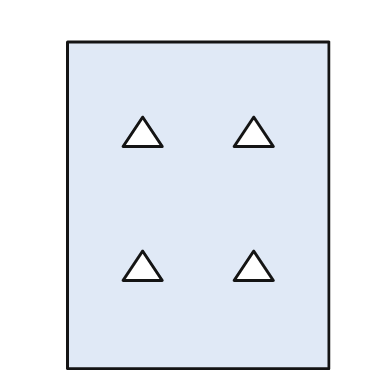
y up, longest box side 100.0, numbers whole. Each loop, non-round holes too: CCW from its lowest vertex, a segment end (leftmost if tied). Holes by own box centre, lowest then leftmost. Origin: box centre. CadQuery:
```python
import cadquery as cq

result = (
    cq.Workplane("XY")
    .moveTo(-40.0, -50.0)
    .lineTo(40.0, -50.0)
    .lineTo(40.0, 50.0)
    .lineTo(-40.0, 50.0)
    .close()
    .moveTo(-23.0, -23.0)
    .lineTo(-11.0, -23.0)
    .lineTo(-17.0, -14.0)
    .close()
    .moveTo(11.0, -23.0)
    .lineTo(23.0, -23.0)
    .lineTo(17.0, -14.0)
    .close()
    .moveTo(-23.0, 18.0)
    .lineTo(-11.0, 18.0)
    .lineTo(-17.0, 27.0)
    .close()
    .moveTo(11.0, 18.0)
    .lineTo(23.0, 18.0)
    .lineTo(17.0, 27.0)
    .close()
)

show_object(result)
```